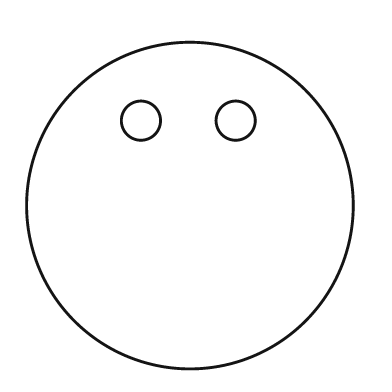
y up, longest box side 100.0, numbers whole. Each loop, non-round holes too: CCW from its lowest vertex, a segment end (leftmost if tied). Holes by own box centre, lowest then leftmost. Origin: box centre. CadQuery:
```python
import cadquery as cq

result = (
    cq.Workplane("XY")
    .moveTo(0.0, 0.0)
    .circle(50.0)
    .moveTo(-15.0, 26.0)
    .circle(6.0)
    .moveTo(14.0, 26.0)
    .circle(6.0)
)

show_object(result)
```